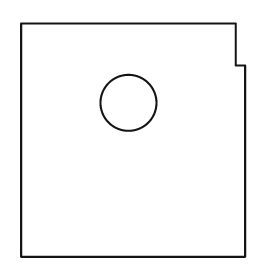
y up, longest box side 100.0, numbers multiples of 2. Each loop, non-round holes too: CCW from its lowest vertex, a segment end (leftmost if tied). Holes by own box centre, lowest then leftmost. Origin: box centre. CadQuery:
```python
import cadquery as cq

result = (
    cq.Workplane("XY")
    .moveTo(-48.0, -50.0)
    .lineTo(48.0, -50.0)
    .lineTo(48.0, 32.0)
    .lineTo(44.0, 32.0)
    .lineTo(44.0, 50.0)
    .lineTo(-48.0, 50.0)
    .close()
    .moveTo(-2.0, 16.0)
    .circle(12.0)
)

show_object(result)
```